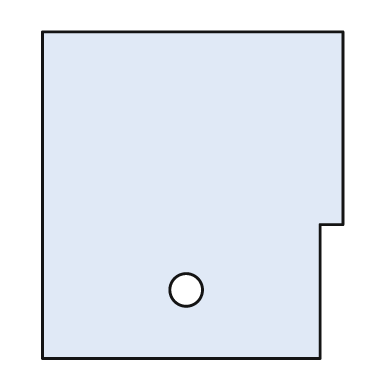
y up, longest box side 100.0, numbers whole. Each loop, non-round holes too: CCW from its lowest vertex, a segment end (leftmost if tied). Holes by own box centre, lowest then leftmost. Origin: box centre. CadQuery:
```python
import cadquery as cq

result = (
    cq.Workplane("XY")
    .moveTo(-46.0, -50.0)
    .lineTo(39.0, -50.0)
    .lineTo(39.0, -9.0)
    .lineTo(46.0, -9.0)
    .lineTo(46.0, 50.0)
    .lineTo(-46.0, 50.0)
    .close()
    .moveTo(-2.0, -29.0)
    .circle(5.0)
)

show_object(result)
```